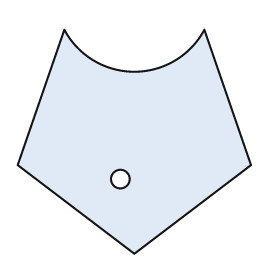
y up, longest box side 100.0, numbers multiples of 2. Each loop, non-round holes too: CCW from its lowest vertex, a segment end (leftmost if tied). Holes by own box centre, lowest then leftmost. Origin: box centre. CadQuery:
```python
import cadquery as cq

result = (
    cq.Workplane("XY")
    .moveTo(0.0, -48.0)
    .lineTo(50.0, -10.0)
    .lineTo(30.0, 48.0)
    .threePointArc((0.0, 30.0), (-30.0, 48.0))
    .lineTo(-50.0, -10.0)
    .close()
    .moveTo(-6.0, -16.0)
    .circle(4.0)
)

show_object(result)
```